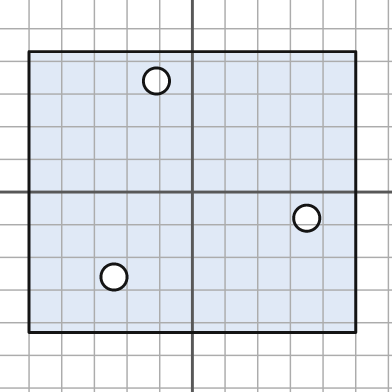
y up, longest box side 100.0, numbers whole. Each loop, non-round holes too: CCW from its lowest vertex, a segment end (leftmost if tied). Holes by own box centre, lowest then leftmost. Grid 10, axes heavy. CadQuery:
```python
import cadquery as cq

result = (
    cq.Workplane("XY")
    .moveTo(-50.0, -43.0)
    .lineTo(50.0, -43.0)
    .lineTo(50.0, 43.0)
    .lineTo(-50.0, 43.0)
    .close()
    .moveTo(-24.0, -26.0)
    .circle(4.0)
    .moveTo(35.0, -8.0)
    .circle(4.0)
    .moveTo(-11.0, 34.0)
    .circle(4.0)
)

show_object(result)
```